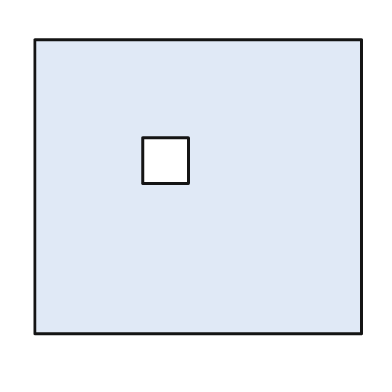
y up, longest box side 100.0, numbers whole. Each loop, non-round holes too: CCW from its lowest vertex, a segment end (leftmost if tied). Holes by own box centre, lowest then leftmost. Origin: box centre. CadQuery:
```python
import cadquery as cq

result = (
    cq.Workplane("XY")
    .moveTo(-50.0, -45.0)
    .lineTo(50.0, -45.0)
    .lineTo(50.0, 45.0)
    .lineTo(-50.0, 45.0)
    .close()
    .moveTo(-17.0, 1.0)
    .lineTo(-3.0, 1.0)
    .lineTo(-3.0, 15.0)
    .lineTo(-17.0, 15.0)
    .close()
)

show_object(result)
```